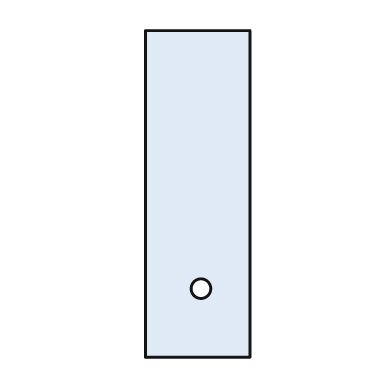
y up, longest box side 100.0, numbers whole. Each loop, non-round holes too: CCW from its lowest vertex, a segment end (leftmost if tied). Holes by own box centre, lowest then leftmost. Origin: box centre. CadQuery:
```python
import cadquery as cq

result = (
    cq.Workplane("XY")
    .moveTo(-16.0, -50.0)
    .lineTo(16.0, -50.0)
    .lineTo(16.0, 50.0)
    .lineTo(-16.0, 50.0)
    .close()
    .moveTo(1.0, -29.0)
    .circle(3.0)
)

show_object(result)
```